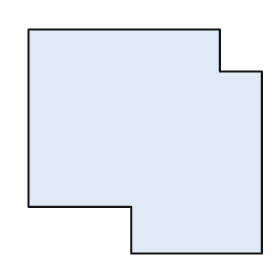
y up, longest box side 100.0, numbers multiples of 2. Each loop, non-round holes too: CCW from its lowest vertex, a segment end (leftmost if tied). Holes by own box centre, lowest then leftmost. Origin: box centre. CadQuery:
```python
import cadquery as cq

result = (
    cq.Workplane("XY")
    .moveTo(-6.0, -48.0)
    .lineTo(50.0, -48.0)
    .lineTo(50.0, 30.0)
    .lineTo(32.0, 30.0)
    .lineTo(32.0, 48.0)
    .lineTo(-50.0, 48.0)
    .lineTo(-50.0, -28.0)
    .lineTo(-6.0, -28.0)
    .close()
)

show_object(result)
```